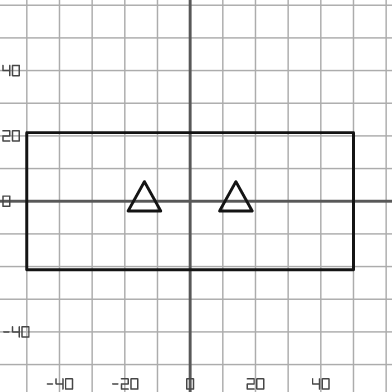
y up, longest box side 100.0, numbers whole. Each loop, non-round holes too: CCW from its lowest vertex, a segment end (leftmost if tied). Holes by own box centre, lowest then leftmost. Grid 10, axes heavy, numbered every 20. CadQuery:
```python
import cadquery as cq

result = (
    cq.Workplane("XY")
    .moveTo(-50.0, -21.0)
    .lineTo(50.0, -21.0)
    .lineTo(50.0, 21.0)
    .lineTo(-50.0, 21.0)
    .close()
    .moveTo(-19.0, -3.0)
    .lineTo(-9.0, -3.0)
    .lineTo(-14.0, 6.0)
    .close()
    .moveTo(9.0, -3.0)
    .lineTo(19.0, -3.0)
    .lineTo(14.0, 6.0)
    .close()
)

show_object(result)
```